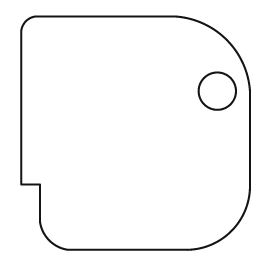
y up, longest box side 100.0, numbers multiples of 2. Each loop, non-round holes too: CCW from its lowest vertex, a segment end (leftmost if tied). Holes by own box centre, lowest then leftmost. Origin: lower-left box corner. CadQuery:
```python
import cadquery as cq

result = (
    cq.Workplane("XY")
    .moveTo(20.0, 0.0)
    .lineTo(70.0, 0.0)
    .threePointArc((90.0, 8.0), (98.0, 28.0))
    .lineTo(98.0, 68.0)
    .threePointArc((88.0, 90.0), (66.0, 100.0))
    .lineTo(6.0, 100.0)
    .threePointArc((2.0, 98.0), (0.0, 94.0))
    .lineTo(0.0, 28.0)
    .lineTo(8.0, 28.0)
    .lineTo(8.0, 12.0)
    .threePointArc((12.0, 4.0), (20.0, 0.0))
    .close()
    .moveTo(84.0, 68.0)
    .circle(8.0)
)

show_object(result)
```